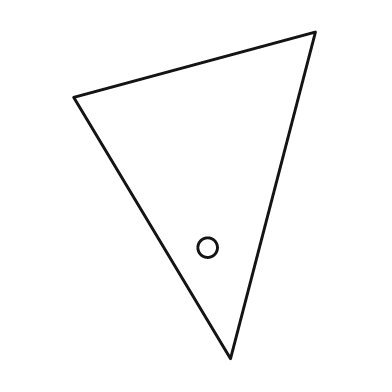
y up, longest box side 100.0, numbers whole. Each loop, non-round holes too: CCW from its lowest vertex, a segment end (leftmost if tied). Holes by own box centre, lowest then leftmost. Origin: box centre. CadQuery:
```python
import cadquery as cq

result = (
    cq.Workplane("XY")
    .moveTo(11.0, -50.0)
    .lineTo(37.0, 50.0)
    .lineTo(-37.0, 30.0)
    .close()
    .moveTo(4.0, -16.0)
    .circle(3.0)
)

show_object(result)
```